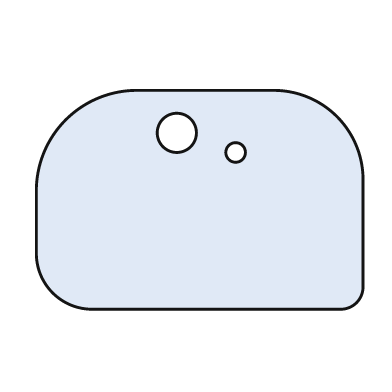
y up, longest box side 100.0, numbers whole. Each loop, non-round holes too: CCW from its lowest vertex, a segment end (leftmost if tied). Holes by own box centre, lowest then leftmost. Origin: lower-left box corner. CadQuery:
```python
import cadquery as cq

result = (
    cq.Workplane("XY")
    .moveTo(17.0, 0.0)
    .lineTo(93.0, 0.0)
    .threePointArc((98.0, 2.0), (100.0, 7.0))
    .lineTo(100.0, 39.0)
    .threePointArc((92.0, 59.0), (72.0, 67.0))
    .lineTo(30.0, 67.0)
    .threePointArc((9.0, 58.0), (0.0, 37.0))
    .lineTo(0.0, 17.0)
    .threePointArc((5.0, 5.0), (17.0, 0.0))
    .close()
    .moveTo(61.0, 48.0)
    .circle(3.0)
    .moveTo(43.0, 54.0)
    .circle(6.0)
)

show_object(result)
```